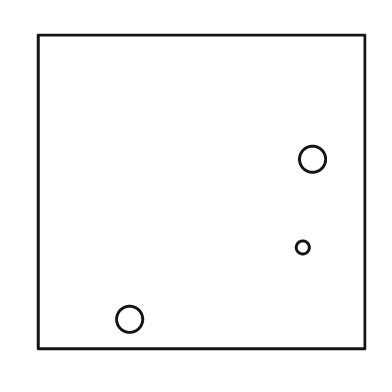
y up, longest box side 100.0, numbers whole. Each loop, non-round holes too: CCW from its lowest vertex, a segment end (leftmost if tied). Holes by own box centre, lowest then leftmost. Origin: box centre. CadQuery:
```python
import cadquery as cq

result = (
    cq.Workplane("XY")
    .moveTo(-50.0, -48.0)
    .lineTo(50.0, -48.0)
    .lineTo(50.0, 48.0)
    .lineTo(-50.0, 48.0)
    .close()
    .moveTo(-22.0, -39.0)
    .circle(4.0)
    .moveTo(31.0, -17.0)
    .circle(2.0)
    .moveTo(34.0, 10.0)
    .circle(4.0)
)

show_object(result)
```